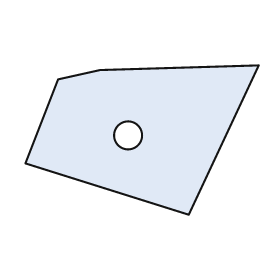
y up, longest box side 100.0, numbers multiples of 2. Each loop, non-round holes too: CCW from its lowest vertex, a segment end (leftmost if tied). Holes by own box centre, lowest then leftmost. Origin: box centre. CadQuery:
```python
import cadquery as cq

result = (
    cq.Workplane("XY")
    .moveTo(20.0, -32.0)
    .lineTo(50.0, 32.0)
    .lineTo(-18.0, 30.0)
    .lineTo(-36.0, 26.0)
    .lineTo(-50.0, -10.0)
    .close()
    .moveTo(-6.0, 2.0)
    .circle(6.0)
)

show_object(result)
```